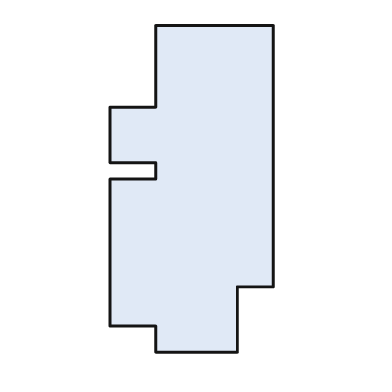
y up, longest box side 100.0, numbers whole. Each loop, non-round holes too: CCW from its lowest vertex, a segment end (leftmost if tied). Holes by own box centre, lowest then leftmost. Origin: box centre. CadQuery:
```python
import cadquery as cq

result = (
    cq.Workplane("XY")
    .moveTo(-11.0, -50.0)
    .lineTo(14.0, -50.0)
    .lineTo(14.0, -30.0)
    .lineTo(25.0, -30.0)
    .lineTo(25.0, 50.0)
    .lineTo(-11.0, 50.0)
    .lineTo(-11.0, 25.0)
    .lineTo(-25.0, 25.0)
    .lineTo(-25.0, 8.0)
    .lineTo(-11.0, 8.0)
    .lineTo(-11.0, 3.0)
    .lineTo(-25.0, 3.0)
    .lineTo(-25.0, -42.0)
    .lineTo(-11.0, -42.0)
    .close()
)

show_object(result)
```